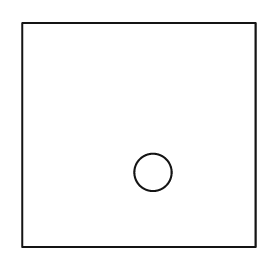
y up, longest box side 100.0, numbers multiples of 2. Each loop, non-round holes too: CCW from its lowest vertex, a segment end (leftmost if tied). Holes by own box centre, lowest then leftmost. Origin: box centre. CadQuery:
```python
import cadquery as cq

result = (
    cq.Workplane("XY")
    .moveTo(-50.0, -48.0)
    .lineTo(50.0, -48.0)
    .lineTo(50.0, 48.0)
    .lineTo(-50.0, 48.0)
    .close()
    .moveTo(6.0, -16.0)
    .circle(8.0)
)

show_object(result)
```